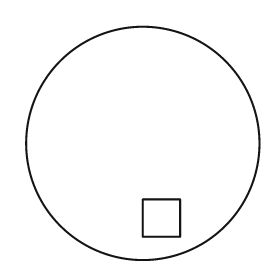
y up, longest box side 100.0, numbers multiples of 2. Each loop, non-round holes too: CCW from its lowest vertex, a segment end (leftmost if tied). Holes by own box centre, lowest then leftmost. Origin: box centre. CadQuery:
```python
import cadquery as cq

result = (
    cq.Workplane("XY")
    .moveTo(0.0, 0.0)
    .circle(50.0)
    .moveTo(0.0, -40.0)
    .lineTo(16.0, -40.0)
    .lineTo(16.0, -24.0)
    .lineTo(0.0, -24.0)
    .close()
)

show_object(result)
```